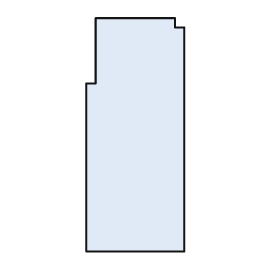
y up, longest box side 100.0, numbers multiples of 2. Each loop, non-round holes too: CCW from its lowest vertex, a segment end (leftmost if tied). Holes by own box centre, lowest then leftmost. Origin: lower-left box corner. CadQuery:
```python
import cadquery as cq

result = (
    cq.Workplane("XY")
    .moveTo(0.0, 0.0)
    .lineTo(42.0, 0.0)
    .lineTo(42.0, 96.0)
    .lineTo(38.0, 96.0)
    .lineTo(38.0, 100.0)
    .lineTo(4.0, 100.0)
    .lineTo(4.0, 72.0)
    .lineTo(0.0, 72.0)
    .close()
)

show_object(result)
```